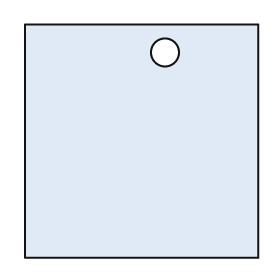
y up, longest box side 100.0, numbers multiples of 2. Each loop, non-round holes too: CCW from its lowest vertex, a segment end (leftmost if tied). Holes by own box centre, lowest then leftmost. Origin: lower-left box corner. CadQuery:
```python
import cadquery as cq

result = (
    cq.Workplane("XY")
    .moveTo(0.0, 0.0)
    .lineTo(100.0, 0.0)
    .lineTo(100.0, 100.0)
    .lineTo(0.0, 100.0)
    .close()
    .moveTo(60.0, 88.0)
    .circle(6.0)
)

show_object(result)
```